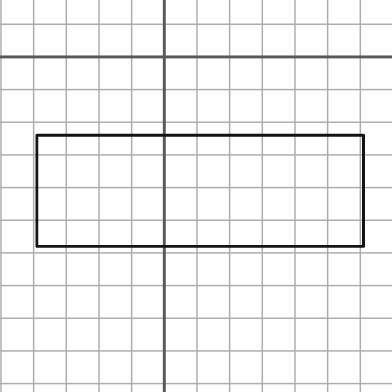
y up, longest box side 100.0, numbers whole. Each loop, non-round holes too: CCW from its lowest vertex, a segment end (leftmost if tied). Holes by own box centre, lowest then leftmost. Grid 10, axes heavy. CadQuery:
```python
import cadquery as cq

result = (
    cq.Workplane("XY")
    .moveTo(-39.0, -58.0)
    .lineTo(61.0, -58.0)
    .lineTo(61.0, -24.0)
    .lineTo(-39.0, -24.0)
    .close()
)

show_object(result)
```